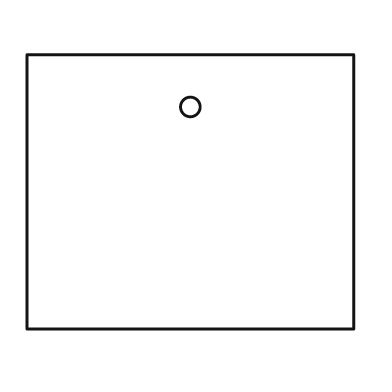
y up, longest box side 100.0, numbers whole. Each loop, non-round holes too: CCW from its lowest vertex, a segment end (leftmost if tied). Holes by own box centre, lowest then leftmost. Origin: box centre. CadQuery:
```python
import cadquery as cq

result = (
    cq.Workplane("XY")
    .moveTo(-50.0, -42.0)
    .lineTo(50.0, -42.0)
    .lineTo(50.0, 42.0)
    .lineTo(-50.0, 42.0)
    .close()
    .moveTo(0.0, 26.0)
    .circle(3.0)
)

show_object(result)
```